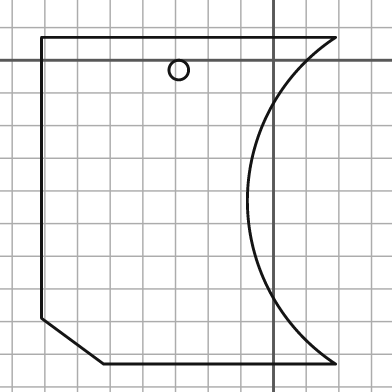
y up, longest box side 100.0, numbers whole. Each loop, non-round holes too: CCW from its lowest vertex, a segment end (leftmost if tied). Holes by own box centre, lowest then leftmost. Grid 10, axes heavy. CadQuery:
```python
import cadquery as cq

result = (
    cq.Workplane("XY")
    .moveTo(-52.0, -93.0)
    .lineTo(19.0, -93.0)
    .threePointArc((-8.0, -43.0), (19.0, 7.0))
    .lineTo(-71.0, 7.0)
    .lineTo(-71.0, -79.0)
    .close()
    .moveTo(-29.0, -3.0)
    .circle(3.0)
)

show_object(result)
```